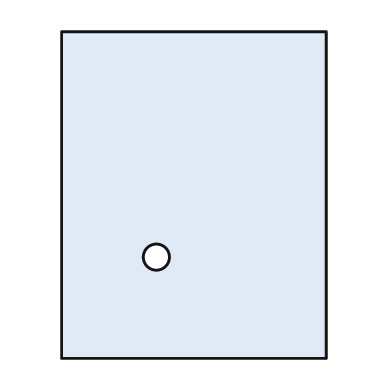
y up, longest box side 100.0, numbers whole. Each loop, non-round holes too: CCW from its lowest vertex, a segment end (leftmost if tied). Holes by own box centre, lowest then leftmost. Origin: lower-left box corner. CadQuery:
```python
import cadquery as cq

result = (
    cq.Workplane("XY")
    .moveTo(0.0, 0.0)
    .lineTo(81.0, 0.0)
    .lineTo(81.0, 100.0)
    .lineTo(0.0, 100.0)
    .close()
    .moveTo(29.0, 31.0)
    .circle(4.0)
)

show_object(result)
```